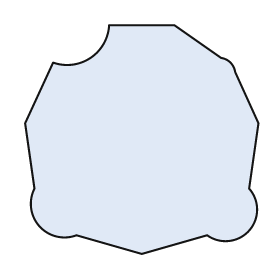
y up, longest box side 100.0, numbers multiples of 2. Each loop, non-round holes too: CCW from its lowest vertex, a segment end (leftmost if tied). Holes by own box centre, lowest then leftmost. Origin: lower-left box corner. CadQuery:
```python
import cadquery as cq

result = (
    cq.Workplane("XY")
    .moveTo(50.0, 0.0)
    .lineTo(78.0, 8.0)
    .threePointArc((96.0, 10.0), (96.0, 28.0))
    .lineTo(100.0, 56.0)
    .lineTo(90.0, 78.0)
    .threePointArc((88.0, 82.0), (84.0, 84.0))
    .lineTo(64.0, 98.0)
    .lineTo(36.0, 98.0)
    .threePointArc((28.0, 84.0), (12.0, 82.0))
    .lineTo(0.0, 56.0)
    .lineTo(4.0, 28.0)
    .threePointArc((6.0, 12.0), (22.0, 8.0))
    .close()
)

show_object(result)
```